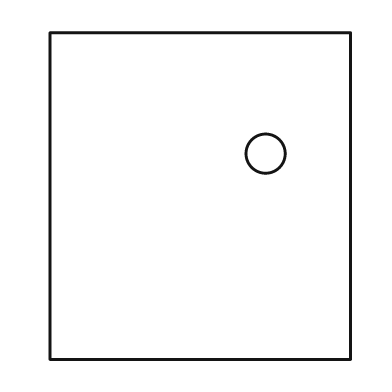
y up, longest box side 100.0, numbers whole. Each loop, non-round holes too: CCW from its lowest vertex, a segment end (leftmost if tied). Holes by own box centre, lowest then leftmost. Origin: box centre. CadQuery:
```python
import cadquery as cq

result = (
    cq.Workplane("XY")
    .moveTo(-46.0, -50.0)
    .lineTo(46.0, -50.0)
    .lineTo(46.0, 50.0)
    .lineTo(-46.0, 50.0)
    .close()
    .moveTo(20.0, 13.0)
    .circle(6.0)
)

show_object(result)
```